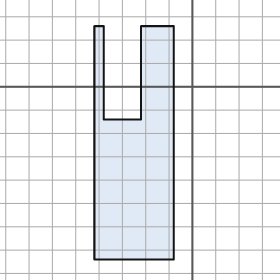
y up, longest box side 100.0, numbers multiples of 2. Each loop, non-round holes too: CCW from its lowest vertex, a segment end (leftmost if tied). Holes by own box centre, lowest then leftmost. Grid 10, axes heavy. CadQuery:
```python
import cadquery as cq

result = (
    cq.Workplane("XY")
    .moveTo(-42.0, -74.0)
    .lineTo(-8.0, -74.0)
    .lineTo(-8.0, 26.0)
    .lineTo(-22.0, 26.0)
    .lineTo(-22.0, -14.0)
    .lineTo(-38.0, -14.0)
    .lineTo(-38.0, 26.0)
    .lineTo(-42.0, 26.0)
    .close()
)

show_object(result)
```